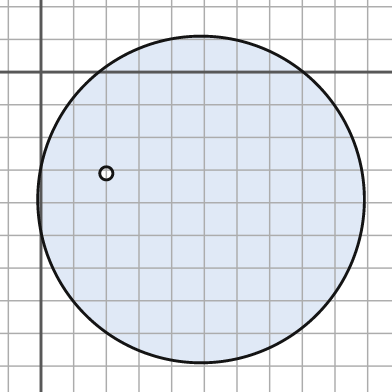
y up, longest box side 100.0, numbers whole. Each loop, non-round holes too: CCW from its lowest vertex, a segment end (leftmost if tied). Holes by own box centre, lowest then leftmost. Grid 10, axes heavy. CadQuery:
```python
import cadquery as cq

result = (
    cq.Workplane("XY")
    .moveTo(49.0, -39.0)
    .circle(50.0)
    .moveTo(20.0, -31.0)
    .circle(2.0)
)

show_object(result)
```